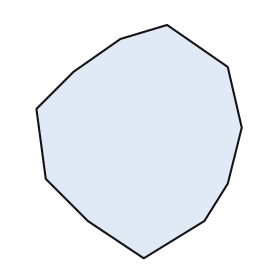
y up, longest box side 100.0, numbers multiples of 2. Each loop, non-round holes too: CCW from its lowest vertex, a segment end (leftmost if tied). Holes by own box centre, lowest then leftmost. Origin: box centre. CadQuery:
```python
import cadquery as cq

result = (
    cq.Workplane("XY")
    .moveTo(2.0, -50.0)
    .lineTo(28.0, -34.0)
    .lineTo(38.0, -18.0)
    .lineTo(44.0, 6.0)
    .lineTo(38.0, 32.0)
    .lineTo(12.0, 50.0)
    .lineTo(-8.0, 44.0)
    .lineTo(-28.0, 30.0)
    .lineTo(-44.0, 14.0)
    .lineTo(-40.0, -16.0)
    .lineTo(-22.0, -34.0)
    .close()
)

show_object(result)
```